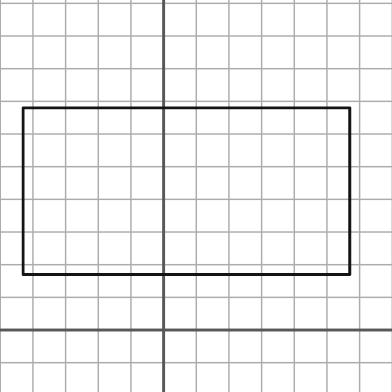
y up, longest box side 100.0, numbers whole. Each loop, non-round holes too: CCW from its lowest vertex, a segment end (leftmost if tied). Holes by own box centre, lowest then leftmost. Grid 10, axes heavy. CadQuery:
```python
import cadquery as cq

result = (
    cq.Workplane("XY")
    .moveTo(-43.0, 17.0)
    .lineTo(57.0, 17.0)
    .lineTo(57.0, 68.0)
    .lineTo(-43.0, 68.0)
    .close()
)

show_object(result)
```